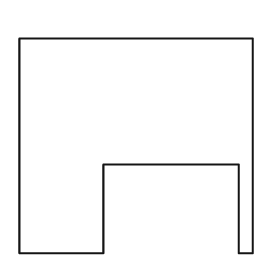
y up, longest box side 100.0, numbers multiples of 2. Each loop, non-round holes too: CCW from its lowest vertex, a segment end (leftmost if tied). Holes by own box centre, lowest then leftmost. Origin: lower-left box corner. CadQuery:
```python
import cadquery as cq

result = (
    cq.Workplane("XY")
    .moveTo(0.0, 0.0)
    .lineTo(36.0, 0.0)
    .lineTo(36.0, 38.0)
    .lineTo(94.0, 38.0)
    .lineTo(94.0, 0.0)
    .lineTo(100.0, 0.0)
    .lineTo(100.0, 92.0)
    .lineTo(0.0, 92.0)
    .close()
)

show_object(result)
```